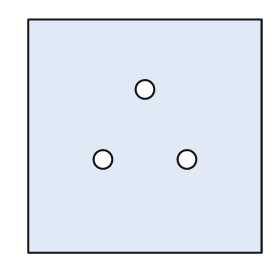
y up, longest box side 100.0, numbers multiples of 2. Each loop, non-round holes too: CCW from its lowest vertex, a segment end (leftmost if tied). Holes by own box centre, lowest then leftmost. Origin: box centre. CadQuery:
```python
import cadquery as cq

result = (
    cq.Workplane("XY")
    .moveTo(-50.0, -50.0)
    .lineTo(50.0, -50.0)
    .lineTo(50.0, 50.0)
    .lineTo(-50.0, 50.0)
    .close()
    .moveTo(-18.0, -10.0)
    .circle(4.0)
    .moveTo(18.0, -10.0)
    .circle(4.0)
    .moveTo(0.0, 20.0)
    .circle(4.0)
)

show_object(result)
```